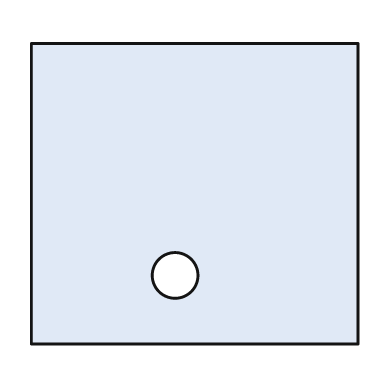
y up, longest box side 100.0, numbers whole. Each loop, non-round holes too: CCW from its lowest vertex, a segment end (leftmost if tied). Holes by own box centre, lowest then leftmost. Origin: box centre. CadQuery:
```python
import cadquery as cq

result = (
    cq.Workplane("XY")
    .moveTo(-50.0, -46.0)
    .lineTo(50.0, -46.0)
    .lineTo(50.0, 46.0)
    .lineTo(-50.0, 46.0)
    .close()
    .moveTo(-6.0, -25.0)
    .circle(7.0)
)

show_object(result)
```